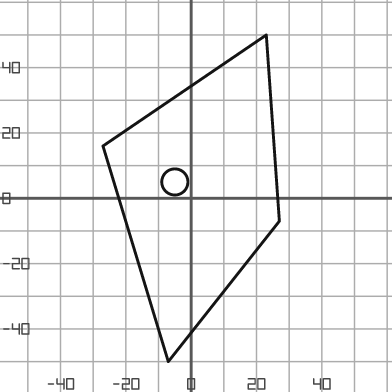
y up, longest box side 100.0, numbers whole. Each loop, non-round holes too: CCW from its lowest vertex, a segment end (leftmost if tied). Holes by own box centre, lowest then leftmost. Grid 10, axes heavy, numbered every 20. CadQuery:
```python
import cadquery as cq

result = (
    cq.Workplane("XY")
    .moveTo(-7.0, -50.0)
    .lineTo(27.0, -7.0)
    .lineTo(23.0, 50.0)
    .lineTo(-27.0, 16.0)
    .close()
    .moveTo(-5.0, 5.0)
    .circle(4.0)
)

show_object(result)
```